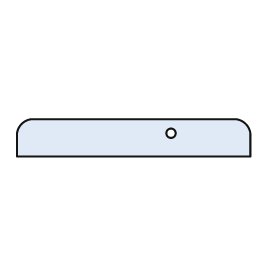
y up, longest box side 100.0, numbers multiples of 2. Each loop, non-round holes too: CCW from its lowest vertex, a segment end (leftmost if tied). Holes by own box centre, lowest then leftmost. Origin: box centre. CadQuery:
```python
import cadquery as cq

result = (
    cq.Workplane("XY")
    .moveTo(-50.0, -8.0)
    .lineTo(50.0, -8.0)
    .lineTo(50.0, 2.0)
    .threePointArc((48.0, 6.0), (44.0, 8.0))
    .lineTo(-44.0, 8.0)
    .threePointArc((-48.0, 6.0), (-50.0, 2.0))
    .close()
    .moveTo(16.0, 2.0)
    .circle(2.0)
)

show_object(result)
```